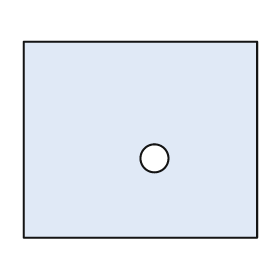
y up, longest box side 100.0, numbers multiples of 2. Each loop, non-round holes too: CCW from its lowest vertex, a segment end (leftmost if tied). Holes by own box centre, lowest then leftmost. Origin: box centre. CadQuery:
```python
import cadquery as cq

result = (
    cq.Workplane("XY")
    .moveTo(-50.0, -42.0)
    .lineTo(50.0, -42.0)
    .lineTo(50.0, 42.0)
    .lineTo(-50.0, 42.0)
    .close()
    .moveTo(6.0, -8.0)
    .circle(6.0)
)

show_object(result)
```